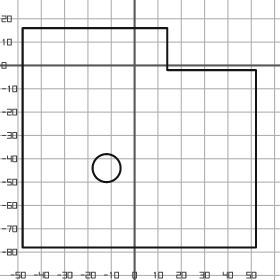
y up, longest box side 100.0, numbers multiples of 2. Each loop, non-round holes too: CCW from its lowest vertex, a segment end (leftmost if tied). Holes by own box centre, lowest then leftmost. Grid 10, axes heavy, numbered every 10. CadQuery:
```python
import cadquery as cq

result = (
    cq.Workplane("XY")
    .moveTo(-48.0, -78.0)
    .lineTo(52.0, -78.0)
    .lineTo(52.0, -2.0)
    .lineTo(14.0, -2.0)
    .lineTo(14.0, 16.0)
    .lineTo(-48.0, 16.0)
    .close()
    .moveTo(-12.0, -44.0)
    .circle(6.0)
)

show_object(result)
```